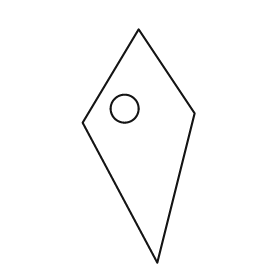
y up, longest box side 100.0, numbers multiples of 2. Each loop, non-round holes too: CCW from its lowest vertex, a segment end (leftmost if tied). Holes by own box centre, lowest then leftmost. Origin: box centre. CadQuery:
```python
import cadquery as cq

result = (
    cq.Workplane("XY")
    .moveTo(8.0, -50.0)
    .lineTo(24.0, 14.0)
    .lineTo(0.0, 50.0)
    .lineTo(-24.0, 10.0)
    .close()
    .moveTo(-6.0, 16.0)
    .circle(6.0)
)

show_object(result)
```